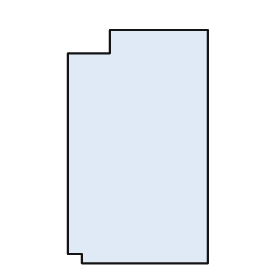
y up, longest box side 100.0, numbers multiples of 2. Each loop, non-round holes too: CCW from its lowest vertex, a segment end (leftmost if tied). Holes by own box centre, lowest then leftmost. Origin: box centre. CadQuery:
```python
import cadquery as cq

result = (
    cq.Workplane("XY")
    .moveTo(-24.0, -50.0)
    .lineTo(30.0, -50.0)
    .lineTo(30.0, 50.0)
    .lineTo(-12.0, 50.0)
    .lineTo(-12.0, 40.0)
    .lineTo(-30.0, 40.0)
    .lineTo(-30.0, -46.0)
    .lineTo(-24.0, -46.0)
    .close()
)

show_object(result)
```